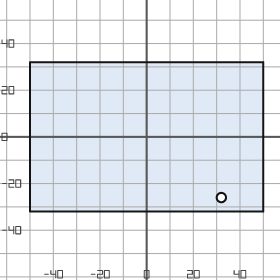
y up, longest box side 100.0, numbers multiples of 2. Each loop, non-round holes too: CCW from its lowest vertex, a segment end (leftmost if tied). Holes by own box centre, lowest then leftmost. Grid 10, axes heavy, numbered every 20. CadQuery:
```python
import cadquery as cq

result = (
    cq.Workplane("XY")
    .moveTo(-50.0, -32.0)
    .lineTo(50.0, -32.0)
    .lineTo(50.0, 32.0)
    .lineTo(-50.0, 32.0)
    .close()
    .moveTo(32.0, -26.0)
    .circle(2.0)
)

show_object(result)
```